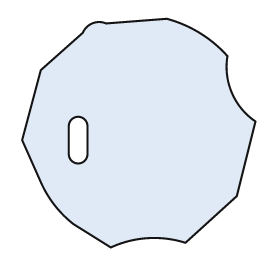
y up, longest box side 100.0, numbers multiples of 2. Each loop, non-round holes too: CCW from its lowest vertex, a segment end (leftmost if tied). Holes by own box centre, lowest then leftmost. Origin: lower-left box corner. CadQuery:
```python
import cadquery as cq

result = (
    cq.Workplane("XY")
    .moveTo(38.0, 0.0)
    .threePointArc((54.0, 4.0), (70.0, 2.0))
    .lineTo(92.0, 22.0)
    .lineTo(100.0, 54.0)
    .threePointArc((90.0, 66.0), (88.0, 82.0))
    .threePointArc((76.0, 92.0), (62.0, 98.0))
    .lineTo(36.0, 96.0)
    .threePointArc((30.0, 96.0), (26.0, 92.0))
    .lineTo(8.0, 76.0)
    .lineTo(0.0, 46.0)
    .lineTo(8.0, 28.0)
    .threePointArc((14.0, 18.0), (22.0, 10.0))
    .close()
    .moveTo(20.0, 40.0)
    .threePointArc((24.0, 36.0), (28.0, 40.0))
    .lineTo(28.0, 52.0)
    .threePointArc((24.0, 56.0), (20.0, 52.0))
    .close()
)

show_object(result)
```